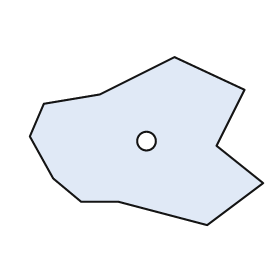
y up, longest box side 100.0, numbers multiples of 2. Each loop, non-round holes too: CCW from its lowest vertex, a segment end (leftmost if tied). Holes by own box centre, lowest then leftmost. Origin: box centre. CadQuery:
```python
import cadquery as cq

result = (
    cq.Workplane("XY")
    .moveTo(26.0, -36.0)
    .lineTo(50.0, -18.0)
    .lineTo(30.0, -2.0)
    .lineTo(42.0, 22.0)
    .lineTo(12.0, 36.0)
    .lineTo(-20.0, 20.0)
    .lineTo(-44.0, 16.0)
    .lineTo(-50.0, 2.0)
    .lineTo(-40.0, -16.0)
    .lineTo(-28.0, -26.0)
    .lineTo(-12.0, -26.0)
    .close()
    .moveTo(0.0, 0.0)
    .circle(4.0)
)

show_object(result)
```